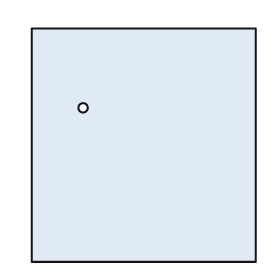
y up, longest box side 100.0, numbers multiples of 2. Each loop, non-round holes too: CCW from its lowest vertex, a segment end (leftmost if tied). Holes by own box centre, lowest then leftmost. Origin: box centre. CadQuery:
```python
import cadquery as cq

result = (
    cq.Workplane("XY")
    .moveTo(-48.0, -50.0)
    .lineTo(48.0, -50.0)
    .lineTo(48.0, 50.0)
    .lineTo(-48.0, 50.0)
    .close()
    .moveTo(-26.0, 16.0)
    .circle(2.0)
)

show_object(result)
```